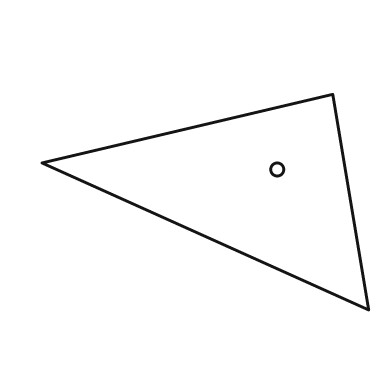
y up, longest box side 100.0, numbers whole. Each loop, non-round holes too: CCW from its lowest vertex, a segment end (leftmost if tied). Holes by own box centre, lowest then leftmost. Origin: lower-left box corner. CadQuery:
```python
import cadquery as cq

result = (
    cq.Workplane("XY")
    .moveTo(100.0, 0.0)
    .lineTo(89.0, 66.0)
    .lineTo(0.0, 45.0)
    .close()
    .moveTo(72.0, 43.0)
    .circle(2.0)
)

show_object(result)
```